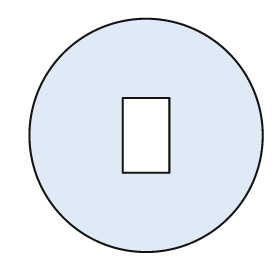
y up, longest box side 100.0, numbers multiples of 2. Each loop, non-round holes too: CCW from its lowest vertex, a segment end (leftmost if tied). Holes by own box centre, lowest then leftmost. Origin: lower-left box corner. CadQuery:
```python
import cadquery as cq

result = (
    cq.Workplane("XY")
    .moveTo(50.0, 50.0)
    .circle(50.0)
    .moveTo(40.0, 34.0)
    .lineTo(60.0, 34.0)
    .lineTo(60.0, 66.0)
    .lineTo(40.0, 66.0)
    .close()
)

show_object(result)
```